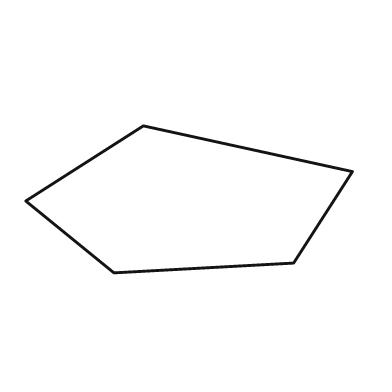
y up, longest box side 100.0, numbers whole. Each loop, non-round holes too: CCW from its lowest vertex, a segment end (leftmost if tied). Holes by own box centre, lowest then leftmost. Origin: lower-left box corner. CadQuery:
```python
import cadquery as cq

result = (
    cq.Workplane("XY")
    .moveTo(27.0, 0.0)
    .lineTo(82.0, 3.0)
    .lineTo(100.0, 31.0)
    .lineTo(36.0, 45.0)
    .lineTo(0.0, 22.0)
    .close()
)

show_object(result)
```